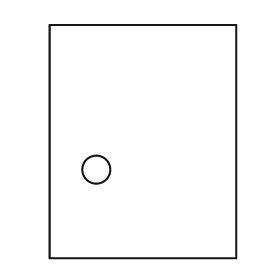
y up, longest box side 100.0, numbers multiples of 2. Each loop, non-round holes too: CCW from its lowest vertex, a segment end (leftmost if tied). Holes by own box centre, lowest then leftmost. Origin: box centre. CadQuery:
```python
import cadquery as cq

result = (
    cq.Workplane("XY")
    .moveTo(-40.0, -50.0)
    .lineTo(40.0, -50.0)
    .lineTo(40.0, 50.0)
    .lineTo(-40.0, 50.0)
    .close()
    .moveTo(-20.0, -12.0)
    .circle(6.0)
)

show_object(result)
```